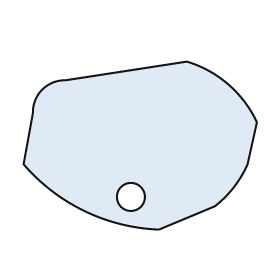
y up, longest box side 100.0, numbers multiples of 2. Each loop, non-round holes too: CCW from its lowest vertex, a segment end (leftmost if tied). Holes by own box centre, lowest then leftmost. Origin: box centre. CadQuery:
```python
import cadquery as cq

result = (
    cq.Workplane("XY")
    .moveTo(8.0, -36.0)
    .lineTo(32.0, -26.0)
    .threePointArc((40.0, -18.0), (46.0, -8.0))
    .lineTo(50.0, 10.0)
    .threePointArc((38.0, 26.0), (20.0, 36.0))
    .lineTo(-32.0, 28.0)
    .threePointArc((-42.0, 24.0), (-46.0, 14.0))
    .lineTo(-50.0, -8.0)
    .threePointArc((-24.0, -28.0), (8.0, -36.0))
    .close()
    .moveTo(-4.0, -22.0)
    .circle(6.0)
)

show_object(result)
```